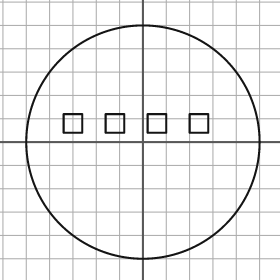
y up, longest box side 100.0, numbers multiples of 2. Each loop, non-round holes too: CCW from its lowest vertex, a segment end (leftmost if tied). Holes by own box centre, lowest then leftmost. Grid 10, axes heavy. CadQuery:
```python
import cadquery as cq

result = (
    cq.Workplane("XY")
    .moveTo(0.0, 0.0)
    .circle(50.0)
    .moveTo(-34.0, 4.0)
    .lineTo(-26.0, 4.0)
    .lineTo(-26.0, 12.0)
    .lineTo(-34.0, 12.0)
    .close()
    .moveTo(-16.0, 4.0)
    .lineTo(-8.0, 4.0)
    .lineTo(-8.0, 12.0)
    .lineTo(-16.0, 12.0)
    .close()
    .moveTo(2.0, 4.0)
    .lineTo(10.0, 4.0)
    .lineTo(10.0, 12.0)
    .lineTo(2.0, 12.0)
    .close()
    .moveTo(20.0, 4.0)
    .lineTo(28.0, 4.0)
    .lineTo(28.0, 12.0)
    .lineTo(20.0, 12.0)
    .close()
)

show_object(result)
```